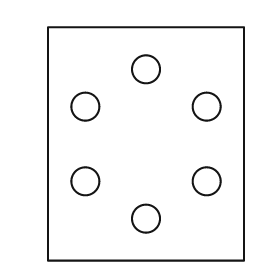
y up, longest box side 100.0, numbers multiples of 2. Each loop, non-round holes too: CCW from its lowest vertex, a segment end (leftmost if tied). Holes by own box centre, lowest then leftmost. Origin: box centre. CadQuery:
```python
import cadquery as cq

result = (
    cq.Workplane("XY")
    .moveTo(-42.0, -50.0)
    .lineTo(42.0, -50.0)
    .lineTo(42.0, 50.0)
    .lineTo(-42.0, 50.0)
    .close()
    .moveTo(0.0, -32.0)
    .circle(6.0)
    .moveTo(-26.0, -16.0)
    .circle(6.0)
    .moveTo(26.0, -16.0)
    .circle(6.0)
    .moveTo(-26.0, 16.0)
    .circle(6.0)
    .moveTo(26.0, 16.0)
    .circle(6.0)
    .moveTo(0.0, 32.0)
    .circle(6.0)
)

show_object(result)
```